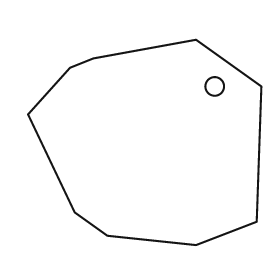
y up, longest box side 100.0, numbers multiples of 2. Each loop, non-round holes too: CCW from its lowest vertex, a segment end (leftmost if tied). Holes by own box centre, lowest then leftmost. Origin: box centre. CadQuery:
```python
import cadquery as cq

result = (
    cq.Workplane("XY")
    .moveTo(22.0, -44.0)
    .lineTo(48.0, -34.0)
    .lineTo(50.0, 24.0)
    .lineTo(22.0, 44.0)
    .lineTo(-22.0, 36.0)
    .lineTo(-32.0, 32.0)
    .lineTo(-50.0, 12.0)
    .lineTo(-30.0, -30.0)
    .lineTo(-16.0, -40.0)
    .close()
    .moveTo(30.0, 24.0)
    .circle(4.0)
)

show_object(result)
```